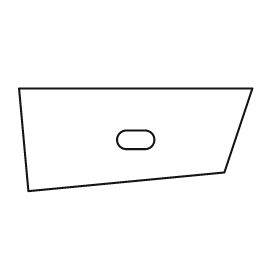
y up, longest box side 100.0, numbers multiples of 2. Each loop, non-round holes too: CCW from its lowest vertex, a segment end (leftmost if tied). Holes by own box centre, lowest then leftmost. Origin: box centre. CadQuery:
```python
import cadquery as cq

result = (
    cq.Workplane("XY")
    .moveTo(-46.0, -22.0)
    .lineTo(38.0, -14.0)
    .lineTo(50.0, 22.0)
    .lineTo(-50.0, 22.0)
    .close()
    .moveTo(-4.0, -4.0)
    .lineTo(4.0, -4.0)
    .threePointArc((8.0, 0.0), (4.0, 4.0))
    .lineTo(-4.0, 4.0)
    .threePointArc((-8.0, 0.0), (-4.0, -4.0))
    .close()
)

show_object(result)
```